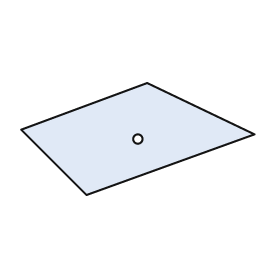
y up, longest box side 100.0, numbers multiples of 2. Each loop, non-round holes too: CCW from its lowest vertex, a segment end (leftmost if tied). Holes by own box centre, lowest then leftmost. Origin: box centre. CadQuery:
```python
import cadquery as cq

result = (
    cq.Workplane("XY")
    .moveTo(-22.0, -24.0)
    .lineTo(50.0, 2.0)
    .lineTo(4.0, 24.0)
    .lineTo(-50.0, 4.0)
    .close()
    .moveTo(0.0, 0.0)
    .circle(2.0)
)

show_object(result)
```